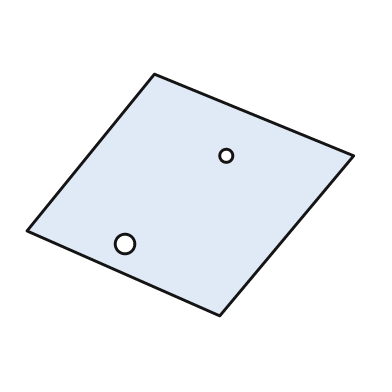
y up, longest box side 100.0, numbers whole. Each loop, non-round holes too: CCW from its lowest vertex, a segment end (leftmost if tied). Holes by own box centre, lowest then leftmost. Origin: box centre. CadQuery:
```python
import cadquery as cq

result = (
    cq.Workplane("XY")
    .moveTo(9.0, -37.0)
    .lineTo(50.0, 12.0)
    .lineTo(-11.0, 37.0)
    .lineTo(-50.0, -11.0)
    .close()
    .moveTo(-20.0, -15.0)
    .circle(3.0)
    .moveTo(11.0, 12.0)
    .circle(2.0)
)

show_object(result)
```